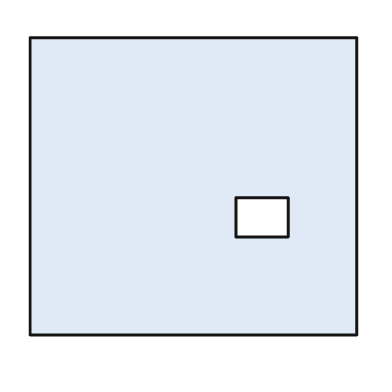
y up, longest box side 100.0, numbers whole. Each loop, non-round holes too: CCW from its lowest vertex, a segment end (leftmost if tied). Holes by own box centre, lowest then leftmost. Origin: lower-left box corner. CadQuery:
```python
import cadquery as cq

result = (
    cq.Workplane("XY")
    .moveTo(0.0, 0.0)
    .lineTo(100.0, 0.0)
    .lineTo(100.0, 91.0)
    .lineTo(0.0, 91.0)
    .close()
    .moveTo(63.0, 30.0)
    .lineTo(79.0, 30.0)
    .lineTo(79.0, 42.0)
    .lineTo(63.0, 42.0)
    .close()
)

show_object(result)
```